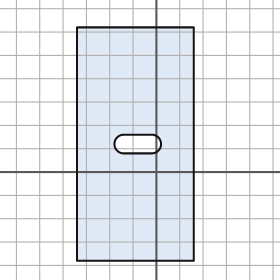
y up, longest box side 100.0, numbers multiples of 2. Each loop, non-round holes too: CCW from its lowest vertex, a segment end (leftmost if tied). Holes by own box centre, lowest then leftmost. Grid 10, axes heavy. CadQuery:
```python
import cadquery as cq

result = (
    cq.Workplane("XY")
    .moveTo(-34.0, -38.0)
    .lineTo(16.0, -38.0)
    .lineTo(16.0, 62.0)
    .lineTo(-34.0, 62.0)
    .close()
    .moveTo(-14.0, 8.0)
    .lineTo(-2.0, 8.0)
    .threePointArc((2.0, 12.0), (-2.0, 16.0))
    .lineTo(-14.0, 16.0)
    .threePointArc((-18.0, 12.0), (-14.0, 8.0))
    .close()
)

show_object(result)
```